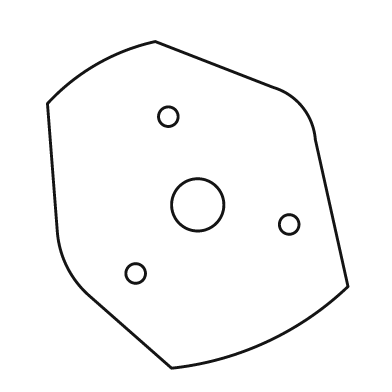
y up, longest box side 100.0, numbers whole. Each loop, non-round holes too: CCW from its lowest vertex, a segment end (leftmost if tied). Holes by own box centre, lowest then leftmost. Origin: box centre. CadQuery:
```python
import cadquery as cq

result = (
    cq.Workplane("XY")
    .moveTo(-8.0, -50.0)
    .threePointArc((21.0, -42.0), (46.0, -25.0))
    .lineTo(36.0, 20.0)
    .threePointArc((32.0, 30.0), (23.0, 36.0))
    .lineTo(-13.0, 50.0)
    .threePointArc((-31.0, 43.0), (-46.0, 31.0))
    .lineTo(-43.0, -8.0)
    .threePointArc((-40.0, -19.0), (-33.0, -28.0))
    .close()
    .moveTo(-19.0, -21.0)
    .circle(3.0)
    .moveTo(28.0, -6.0)
    .circle(3.0)
    .moveTo(0.0, 0.0)
    .circle(8.0)
    .moveTo(-9.0, 27.0)
    .circle(3.0)
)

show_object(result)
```